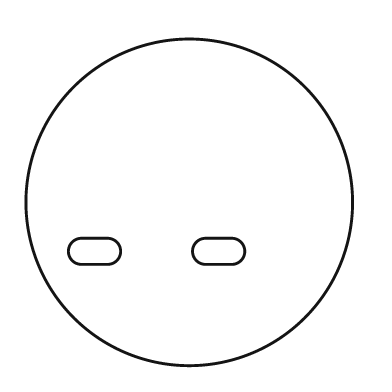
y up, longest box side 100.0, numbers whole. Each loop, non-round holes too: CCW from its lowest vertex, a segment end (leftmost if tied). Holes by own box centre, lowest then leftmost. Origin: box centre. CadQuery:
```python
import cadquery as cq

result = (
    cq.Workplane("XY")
    .moveTo(0.0, 0.0)
    .circle(50.0)
    .moveTo(-33.0, -19.0)
    .lineTo(-25.0, -19.0)
    .threePointArc((-21.0, -15.0), (-25.0, -11.0))
    .lineTo(-33.0, -11.0)
    .threePointArc((-37.0, -15.0), (-33.0, -19.0))
    .close()
    .moveTo(5.0, -19.0)
    .lineTo(13.0, -19.0)
    .threePointArc((17.0, -15.0), (13.0, -11.0))
    .lineTo(5.0, -11.0)
    .threePointArc((1.0, -15.0), (5.0, -19.0))
    .close()
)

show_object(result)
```